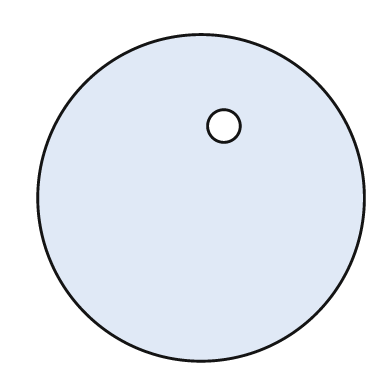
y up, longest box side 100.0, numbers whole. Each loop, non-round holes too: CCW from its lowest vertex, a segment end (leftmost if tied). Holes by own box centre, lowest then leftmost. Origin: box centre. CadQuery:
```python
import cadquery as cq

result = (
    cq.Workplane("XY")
    .moveTo(0.0, 0.0)
    .circle(50.0)
    .moveTo(7.0, 22.0)
    .circle(5.0)
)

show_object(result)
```